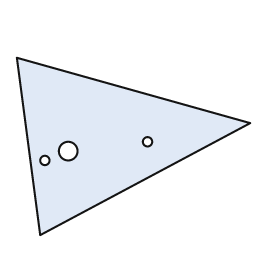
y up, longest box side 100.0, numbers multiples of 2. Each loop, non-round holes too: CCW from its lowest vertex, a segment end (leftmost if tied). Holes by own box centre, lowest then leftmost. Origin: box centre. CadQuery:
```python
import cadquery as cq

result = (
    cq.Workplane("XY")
    .moveTo(-40.0, -38.0)
    .lineTo(50.0, 10.0)
    .lineTo(-50.0, 38.0)
    .close()
    .moveTo(-38.0, -6.0)
    .circle(2.0)
    .moveTo(-28.0, -2.0)
    .circle(4.0)
    .moveTo(6.0, 2.0)
    .circle(2.0)
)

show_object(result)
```